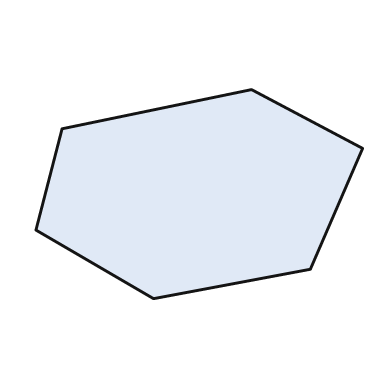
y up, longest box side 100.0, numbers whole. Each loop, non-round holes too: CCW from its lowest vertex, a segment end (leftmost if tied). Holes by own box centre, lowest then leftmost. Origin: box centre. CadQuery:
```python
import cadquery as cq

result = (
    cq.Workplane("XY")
    .moveTo(-14.0, -32.0)
    .lineTo(34.0, -23.0)
    .lineTo(50.0, 14.0)
    .lineTo(16.0, 32.0)
    .lineTo(-42.0, 20.0)
    .lineTo(-50.0, -11.0)
    .close()
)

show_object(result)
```